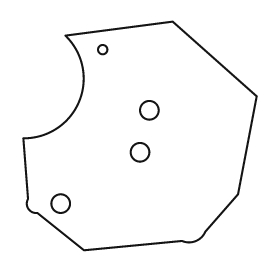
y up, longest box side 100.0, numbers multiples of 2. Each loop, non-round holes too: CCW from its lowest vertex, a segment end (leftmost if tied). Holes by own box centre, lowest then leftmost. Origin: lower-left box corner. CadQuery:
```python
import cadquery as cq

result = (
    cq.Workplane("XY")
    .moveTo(26.0, 0.0)
    .lineTo(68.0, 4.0)
    .threePointArc((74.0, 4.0), (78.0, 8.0))
    .lineTo(92.0, 24.0)
    .lineTo(100.0, 66.0)
    .lineTo(64.0, 98.0)
    .lineTo(18.0, 92.0)
    .threePointArc((24.0, 64.0), (0.0, 48.0))
    .lineTo(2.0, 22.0)
    .threePointArc((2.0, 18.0), (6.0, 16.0))
    .close()
    .moveTo(16.0, 20.0)
    .circle(4.0)
    .moveTo(50.0, 42.0)
    .circle(4.0)
    .moveTo(54.0, 60.0)
    .circle(4.0)
    .moveTo(34.0, 86.0)
    .circle(2.0)
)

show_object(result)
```